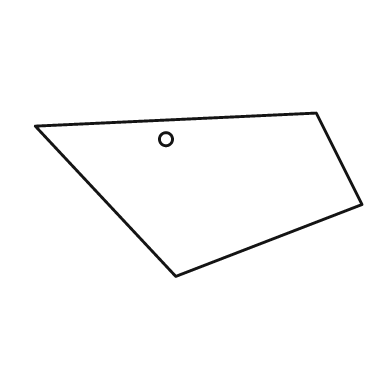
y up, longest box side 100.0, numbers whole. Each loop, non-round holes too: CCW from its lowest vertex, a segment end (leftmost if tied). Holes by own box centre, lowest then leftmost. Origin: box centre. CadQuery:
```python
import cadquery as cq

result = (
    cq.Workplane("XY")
    .moveTo(-7.0, -25.0)
    .lineTo(50.0, -3.0)
    .lineTo(36.0, 25.0)
    .lineTo(-50.0, 21.0)
    .close()
    .moveTo(-10.0, 17.0)
    .circle(2.0)
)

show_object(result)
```